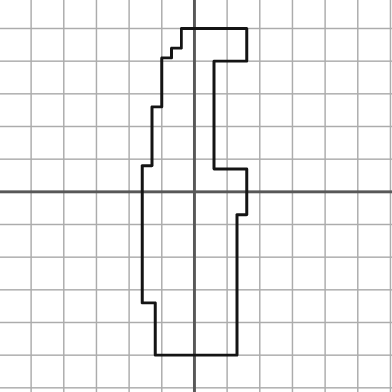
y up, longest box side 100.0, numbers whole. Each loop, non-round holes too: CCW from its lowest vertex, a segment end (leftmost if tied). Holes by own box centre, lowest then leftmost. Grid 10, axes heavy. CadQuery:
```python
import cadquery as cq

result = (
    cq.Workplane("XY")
    .moveTo(-12.0, -50.0)
    .lineTo(13.0, -50.0)
    .lineTo(13.0, -7.0)
    .lineTo(16.0, -7.0)
    .lineTo(16.0, 7.0)
    .lineTo(6.0, 7.0)
    .lineTo(6.0, 40.0)
    .lineTo(16.0, 40.0)
    .lineTo(16.0, 50.0)
    .lineTo(-4.0, 50.0)
    .lineTo(-4.0, 44.0)
    .lineTo(-7.0, 44.0)
    .lineTo(-7.0, 41.0)
    .lineTo(-10.0, 41.0)
    .lineTo(-10.0, 26.0)
    .lineTo(-13.0, 26.0)
    .lineTo(-13.0, 8.0)
    .lineTo(-16.0, 8.0)
    .lineTo(-16.0, -34.0)
    .lineTo(-12.0, -34.0)
    .close()
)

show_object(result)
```